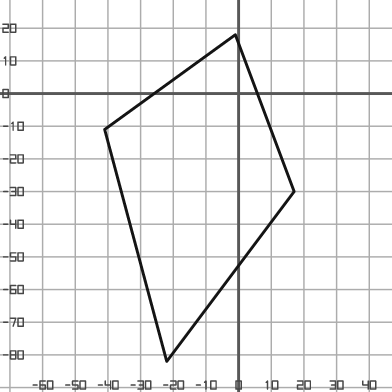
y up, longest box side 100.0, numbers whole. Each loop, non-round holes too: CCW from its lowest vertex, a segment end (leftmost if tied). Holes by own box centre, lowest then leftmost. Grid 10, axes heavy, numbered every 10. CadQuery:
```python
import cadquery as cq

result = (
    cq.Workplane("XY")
    .moveTo(-22.0, -82.0)
    .lineTo(17.0, -30.0)
    .lineTo(-1.0, 18.0)
    .lineTo(-41.0, -11.0)
    .close()
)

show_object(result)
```